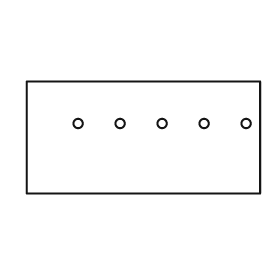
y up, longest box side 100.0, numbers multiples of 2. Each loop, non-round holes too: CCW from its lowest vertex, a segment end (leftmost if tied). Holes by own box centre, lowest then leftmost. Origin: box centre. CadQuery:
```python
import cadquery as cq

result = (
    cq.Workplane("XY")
    .moveTo(-50.0, -24.0)
    .lineTo(50.0, -24.0)
    .lineTo(50.0, 24.0)
    .lineTo(-50.0, 24.0)
    .close()
    .moveTo(-28.0, 6.0)
    .circle(2.0)
    .moveTo(-10.0, 6.0)
    .circle(2.0)
    .moveTo(8.0, 6.0)
    .circle(2.0)
    .moveTo(26.0, 6.0)
    .circle(2.0)
    .moveTo(44.0, 6.0)
    .circle(2.0)
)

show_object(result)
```